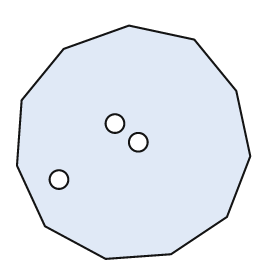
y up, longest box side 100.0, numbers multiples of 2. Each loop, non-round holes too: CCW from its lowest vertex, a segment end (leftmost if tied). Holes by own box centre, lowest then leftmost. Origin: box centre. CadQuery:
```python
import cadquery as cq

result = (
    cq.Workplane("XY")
    .moveTo(-12.0, -50.0)
    .lineTo(16.0, -48.0)
    .lineTo(40.0, -32.0)
    .lineTo(50.0, -6.0)
    .lineTo(44.0, 22.0)
    .lineTo(26.0, 44.0)
    .lineTo(-2.0, 50.0)
    .lineTo(-30.0, 40.0)
    .lineTo(-48.0, 18.0)
    .lineTo(-50.0, -10.0)
    .lineTo(-38.0, -36.0)
    .close()
    .moveTo(-32.0, -16.0)
    .circle(4.0)
    .moveTo(2.0, 0.0)
    .circle(4.0)
    .moveTo(-8.0, 8.0)
    .circle(4.0)
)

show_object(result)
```